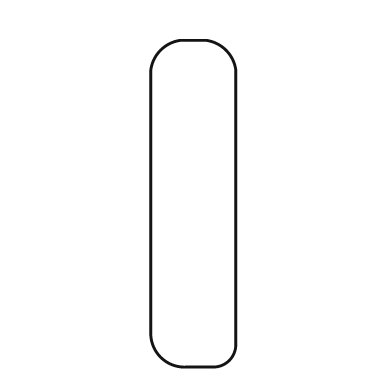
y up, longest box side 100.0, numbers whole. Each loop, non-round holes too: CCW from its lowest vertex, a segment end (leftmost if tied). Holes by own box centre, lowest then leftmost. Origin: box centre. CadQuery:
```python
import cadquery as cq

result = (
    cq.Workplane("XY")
    .moveTo(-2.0, -50.0)
    .lineTo(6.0, -50.0)
    .threePointArc((11.0, -48.0), (13.0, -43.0))
    .lineTo(13.0, 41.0)
    .threePointArc((10.0, 47.0), (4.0, 50.0))
    .lineTo(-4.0, 50.0)
    .threePointArc((-10.0, 47.0), (-13.0, 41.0))
    .lineTo(-13.0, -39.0)
    .threePointArc((-10.0, -47.0), (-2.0, -50.0))
    .close()
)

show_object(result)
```